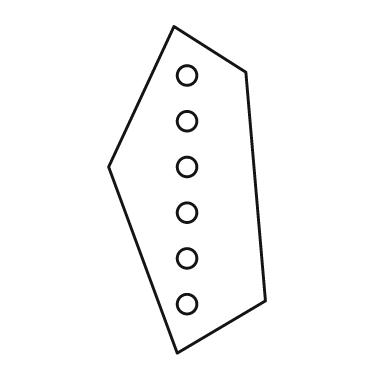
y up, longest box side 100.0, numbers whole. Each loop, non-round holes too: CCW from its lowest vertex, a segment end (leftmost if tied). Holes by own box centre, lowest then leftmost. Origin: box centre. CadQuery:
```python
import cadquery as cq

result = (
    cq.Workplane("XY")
    .moveTo(-3.0, -50.0)
    .lineTo(24.0, -34.0)
    .lineTo(18.0, 36.0)
    .lineTo(-4.0, 50.0)
    .lineTo(-24.0, 7.0)
    .close()
    .moveTo(0.0, -35.0)
    .circle(3.0)
    .moveTo(0.0, -21.0)
    .circle(3.0)
    .moveTo(0.0, -7.0)
    .circle(3.0)
    .moveTo(0.0, 7.0)
    .circle(3.0)
    .moveTo(0.0, 21.0)
    .circle(3.0)
    .moveTo(0.0, 35.0)
    .circle(3.0)
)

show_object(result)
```